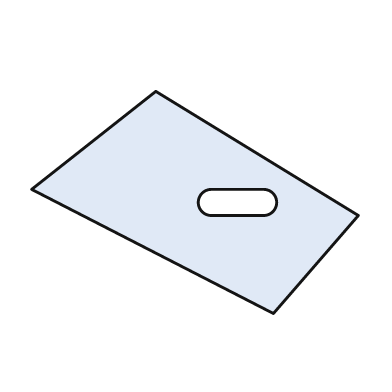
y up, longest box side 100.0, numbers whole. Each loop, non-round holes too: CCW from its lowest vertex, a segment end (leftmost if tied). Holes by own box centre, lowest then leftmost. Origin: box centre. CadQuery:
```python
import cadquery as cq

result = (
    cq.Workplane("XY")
    .moveTo(24.0, -34.0)
    .lineTo(50.0, -4.0)
    .lineTo(-12.0, 34.0)
    .lineTo(-50.0, 4.0)
    .close()
    .moveTo(5.0, -4.0)
    .lineTo(21.0, -4.0)
    .threePointArc((25.0, 0.0), (21.0, 4.0))
    .lineTo(5.0, 4.0)
    .threePointArc((1.0, 0.0), (5.0, -4.0))
    .close()
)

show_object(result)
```